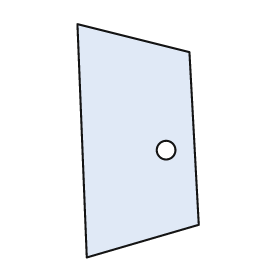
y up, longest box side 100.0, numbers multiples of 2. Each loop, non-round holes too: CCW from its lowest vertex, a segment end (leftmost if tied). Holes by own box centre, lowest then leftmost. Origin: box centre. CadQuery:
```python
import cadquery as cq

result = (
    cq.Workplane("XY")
    .moveTo(-22.0, -50.0)
    .lineTo(26.0, -36.0)
    .lineTo(22.0, 38.0)
    .lineTo(-26.0, 50.0)
    .close()
    .moveTo(12.0, -4.0)
    .circle(4.0)
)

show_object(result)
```